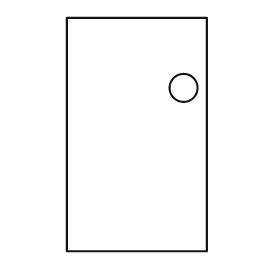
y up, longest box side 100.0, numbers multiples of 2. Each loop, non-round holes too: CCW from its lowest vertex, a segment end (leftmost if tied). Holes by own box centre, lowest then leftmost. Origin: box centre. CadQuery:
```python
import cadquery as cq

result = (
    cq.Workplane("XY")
    .moveTo(-30.0, -50.0)
    .lineTo(30.0, -50.0)
    .lineTo(30.0, 50.0)
    .lineTo(-30.0, 50.0)
    .close()
    .moveTo(20.0, 20.0)
    .circle(6.0)
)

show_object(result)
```